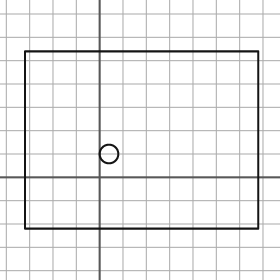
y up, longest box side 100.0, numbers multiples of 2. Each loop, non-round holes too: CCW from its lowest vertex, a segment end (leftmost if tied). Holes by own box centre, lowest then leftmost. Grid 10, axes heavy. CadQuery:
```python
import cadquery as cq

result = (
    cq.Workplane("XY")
    .moveTo(-32.0, -22.0)
    .lineTo(68.0, -22.0)
    .lineTo(68.0, 54.0)
    .lineTo(-32.0, 54.0)
    .close()
    .moveTo(4.0, 10.0)
    .circle(4.0)
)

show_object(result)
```